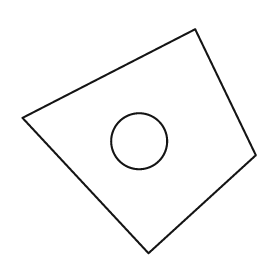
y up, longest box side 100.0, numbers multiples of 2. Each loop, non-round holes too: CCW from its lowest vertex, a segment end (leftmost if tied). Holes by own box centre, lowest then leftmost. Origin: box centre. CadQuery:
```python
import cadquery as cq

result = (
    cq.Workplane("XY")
    .moveTo(4.0, -48.0)
    .lineTo(50.0, -6.0)
    .lineTo(24.0, 48.0)
    .lineTo(-50.0, 10.0)
    .close()
    .moveTo(0.0, 0.0)
    .circle(12.0)
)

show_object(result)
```